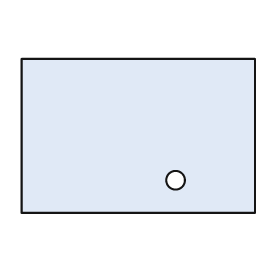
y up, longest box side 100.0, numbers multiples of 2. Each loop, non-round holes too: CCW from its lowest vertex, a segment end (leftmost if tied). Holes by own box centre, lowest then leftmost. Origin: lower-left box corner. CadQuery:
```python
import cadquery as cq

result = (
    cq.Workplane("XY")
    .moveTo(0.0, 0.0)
    .lineTo(100.0, 0.0)
    .lineTo(100.0, 66.0)
    .lineTo(0.0, 66.0)
    .close()
    .moveTo(66.0, 14.0)
    .circle(4.0)
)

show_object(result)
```